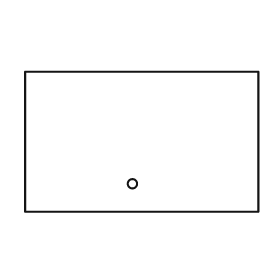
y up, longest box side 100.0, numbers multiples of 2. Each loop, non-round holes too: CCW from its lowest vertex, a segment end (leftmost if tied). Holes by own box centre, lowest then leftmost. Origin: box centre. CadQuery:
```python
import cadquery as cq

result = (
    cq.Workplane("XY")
    .moveTo(-50.0, -30.0)
    .lineTo(50.0, -30.0)
    .lineTo(50.0, 30.0)
    .lineTo(-50.0, 30.0)
    .close()
    .moveTo(-4.0, -18.0)
    .circle(2.0)
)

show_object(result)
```